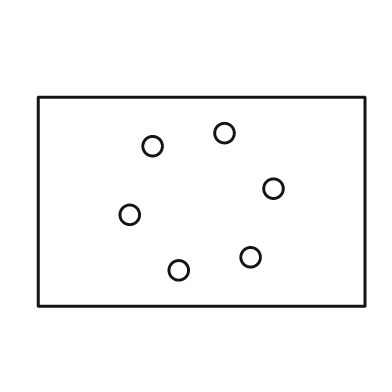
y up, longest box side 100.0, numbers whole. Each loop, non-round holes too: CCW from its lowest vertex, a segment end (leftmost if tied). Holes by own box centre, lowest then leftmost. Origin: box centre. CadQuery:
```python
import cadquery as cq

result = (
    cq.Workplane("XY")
    .moveTo(-50.0, -32.0)
    .lineTo(50.0, -32.0)
    .lineTo(50.0, 32.0)
    .lineTo(-50.0, 32.0)
    .close()
    .moveTo(-7.0, -21.0)
    .circle(3.0)
    .moveTo(15.0, -17.0)
    .circle(3.0)
    .moveTo(-22.0, -4.0)
    .circle(3.0)
    .moveTo(22.0, 4.0)
    .circle(3.0)
    .moveTo(-15.0, 17.0)
    .circle(3.0)
    .moveTo(7.0, 21.0)
    .circle(3.0)
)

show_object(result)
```